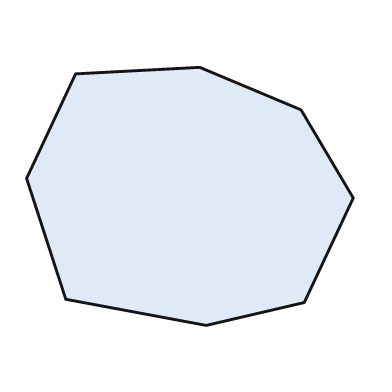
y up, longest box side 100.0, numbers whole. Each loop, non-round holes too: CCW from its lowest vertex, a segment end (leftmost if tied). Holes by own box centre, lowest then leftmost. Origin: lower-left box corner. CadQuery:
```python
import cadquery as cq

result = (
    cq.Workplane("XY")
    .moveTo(55.0, 0.0)
    .lineTo(85.0, 7.0)
    .lineTo(100.0, 39.0)
    .lineTo(84.0, 66.0)
    .lineTo(53.0, 79.0)
    .lineTo(15.0, 77.0)
    .lineTo(0.0, 45.0)
    .lineTo(12.0, 8.0)
    .close()
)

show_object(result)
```